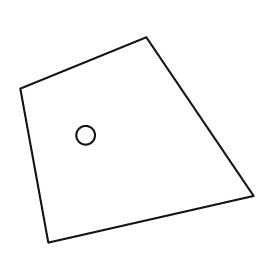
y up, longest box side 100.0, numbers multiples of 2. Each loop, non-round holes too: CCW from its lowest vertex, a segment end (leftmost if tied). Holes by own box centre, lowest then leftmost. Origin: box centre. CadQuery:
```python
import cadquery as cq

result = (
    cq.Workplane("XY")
    .moveTo(-38.0, -44.0)
    .lineTo(50.0, -24.0)
    .lineTo(4.0, 44.0)
    .lineTo(-50.0, 22.0)
    .close()
    .moveTo(-22.0, 2.0)
    .circle(4.0)
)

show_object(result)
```